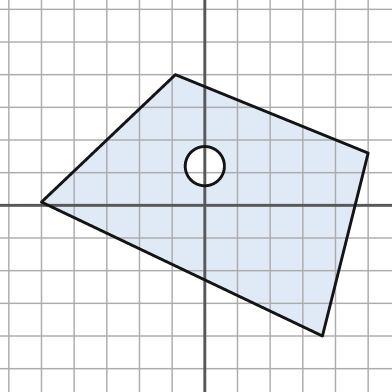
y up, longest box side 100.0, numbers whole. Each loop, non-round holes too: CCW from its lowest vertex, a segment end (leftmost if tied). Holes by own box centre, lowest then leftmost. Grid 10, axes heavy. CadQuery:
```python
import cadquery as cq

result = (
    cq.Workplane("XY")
    .moveTo(36.0, -40.0)
    .lineTo(50.0, 16.0)
    .lineTo(-9.0, 40.0)
    .lineTo(-50.0, 1.0)
    .close()
    .moveTo(0.0, 12.0)
    .circle(6.0)
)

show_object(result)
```